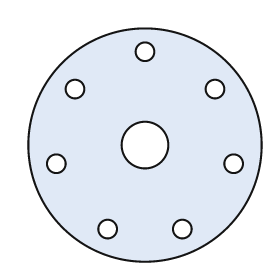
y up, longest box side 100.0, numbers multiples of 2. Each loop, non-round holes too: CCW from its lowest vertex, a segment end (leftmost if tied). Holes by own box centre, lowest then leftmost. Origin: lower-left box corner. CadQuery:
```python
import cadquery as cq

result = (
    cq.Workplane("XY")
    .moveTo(50.0, 50.0)
    .circle(50.0)
    .moveTo(34.0, 14.0)
    .circle(4.0)
    .moveTo(66.0, 14.0)
    .circle(4.0)
    .moveTo(12.0, 42.0)
    .circle(4.0)
    .moveTo(88.0, 42.0)
    .circle(4.0)
    .moveTo(50.0, 50.0)
    .circle(10.0)
    .moveTo(20.0, 74.0)
    .circle(4.0)
    .moveTo(80.0, 74.0)
    .circle(4.0)
    .moveTo(50.0, 90.0)
    .circle(4.0)
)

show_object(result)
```